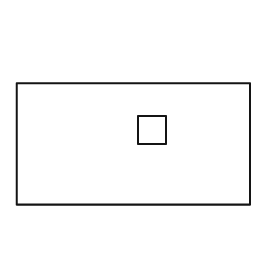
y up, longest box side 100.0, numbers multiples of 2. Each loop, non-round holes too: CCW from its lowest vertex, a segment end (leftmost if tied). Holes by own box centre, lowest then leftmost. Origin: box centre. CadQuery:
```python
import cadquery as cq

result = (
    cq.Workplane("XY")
    .moveTo(-50.0, -26.0)
    .lineTo(50.0, -26.0)
    .lineTo(50.0, 26.0)
    .lineTo(-50.0, 26.0)
    .close()
    .moveTo(2.0, 0.0)
    .lineTo(14.0, 0.0)
    .lineTo(14.0, 12.0)
    .lineTo(2.0, 12.0)
    .close()
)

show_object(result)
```